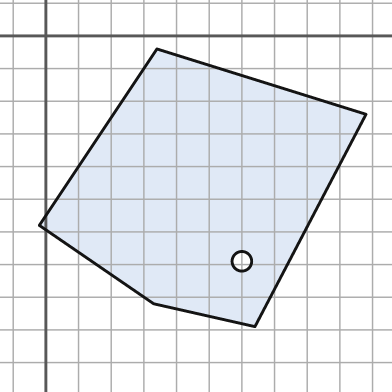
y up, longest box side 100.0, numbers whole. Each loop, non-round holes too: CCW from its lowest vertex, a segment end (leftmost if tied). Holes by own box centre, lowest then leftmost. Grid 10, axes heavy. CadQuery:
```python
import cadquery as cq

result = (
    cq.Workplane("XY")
    .moveTo(64.0, -89.0)
    .lineTo(98.0, -24.0)
    .lineTo(34.0, -4.0)
    .lineTo(-2.0, -58.0)
    .lineTo(33.0, -82.0)
    .close()
    .moveTo(60.0, -69.0)
    .circle(3.0)
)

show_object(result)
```